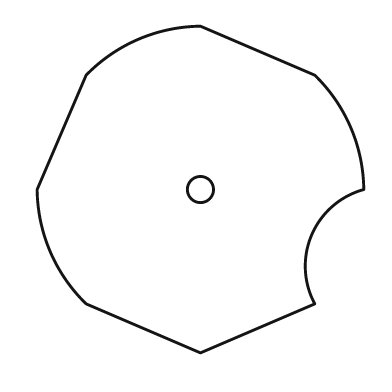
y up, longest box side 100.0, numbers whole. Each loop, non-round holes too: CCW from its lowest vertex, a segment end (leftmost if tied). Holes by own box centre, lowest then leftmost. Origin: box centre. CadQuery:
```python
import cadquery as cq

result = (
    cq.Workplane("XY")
    .moveTo(0.0, -50.0)
    .lineTo(35.0, -35.0)
    .threePointArc((34.0, -14.0), (50.0, 0.0))
    .threePointArc((46.0, 19.0), (35.0, 35.0))
    .lineTo(0.0, 50.0)
    .threePointArc((-19.0, 46.0), (-35.0, 35.0))
    .lineTo(-50.0, 0.0)
    .threePointArc((-46.0, -19.0), (-35.0, -35.0))
    .close()
    .moveTo(0.0, 0.0)
    .circle(4.0)
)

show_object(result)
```